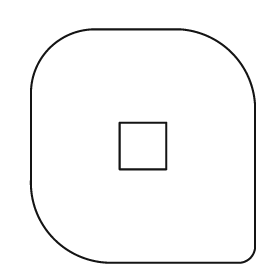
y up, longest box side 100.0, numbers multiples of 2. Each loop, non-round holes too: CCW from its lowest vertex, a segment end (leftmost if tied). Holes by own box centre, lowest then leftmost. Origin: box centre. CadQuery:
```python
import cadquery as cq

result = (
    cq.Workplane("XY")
    .moveTo(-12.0, -50.0)
    .lineTo(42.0, -50.0)
    .threePointArc((46.0, -48.0), (48.0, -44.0))
    .lineTo(48.0, 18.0)
    .threePointArc((38.0, 40.0), (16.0, 50.0))
    .lineTo(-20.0, 50.0)
    .threePointArc((-40.0, 42.0), (-48.0, 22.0))
    .lineTo(-48.0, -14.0)
    .threePointArc((-38.0, -40.0), (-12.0, -50.0))
    .close()
    .moveTo(-10.0, -10.0)
    .lineTo(10.0, -10.0)
    .lineTo(10.0, 10.0)
    .lineTo(-10.0, 10.0)
    .close()
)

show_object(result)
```